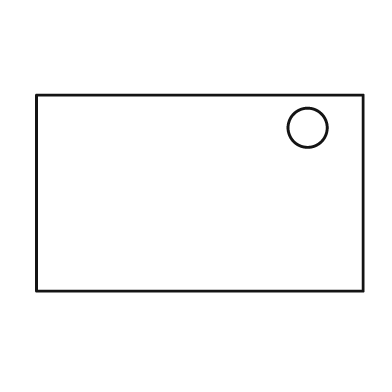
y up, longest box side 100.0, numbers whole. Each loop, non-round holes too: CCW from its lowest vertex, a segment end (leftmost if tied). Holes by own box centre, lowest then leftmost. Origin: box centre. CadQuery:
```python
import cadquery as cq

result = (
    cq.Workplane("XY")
    .moveTo(-50.0, -30.0)
    .lineTo(50.0, -30.0)
    .lineTo(50.0, 30.0)
    .lineTo(-50.0, 30.0)
    .close()
    .moveTo(33.0, 20.0)
    .circle(6.0)
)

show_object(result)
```